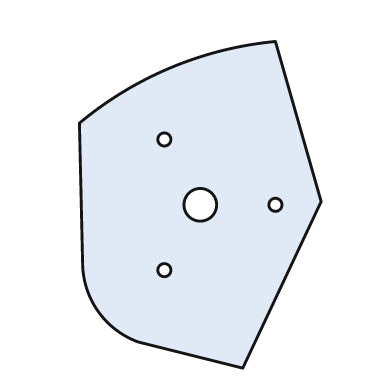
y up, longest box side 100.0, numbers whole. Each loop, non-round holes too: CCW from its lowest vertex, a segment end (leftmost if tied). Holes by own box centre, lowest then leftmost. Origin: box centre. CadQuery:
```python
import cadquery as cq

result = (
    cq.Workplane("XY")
    .moveTo(13.0, -50.0)
    .lineTo(37.0, 1.0)
    .lineTo(23.0, 50.0)
    .threePointArc((-9.0, 42.0), (-37.0, 25.0))
    .lineTo(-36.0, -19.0)
    .threePointArc((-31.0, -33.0), (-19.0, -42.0))
    .close()
    .moveTo(-11.0, -20.0)
    .circle(2.0)
    .moveTo(0.0, 0.0)
    .circle(5.0)
    .moveTo(23.0, 0.0)
    .circle(2.0)
    .moveTo(-11.0, 20.0)
    .circle(2.0)
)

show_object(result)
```